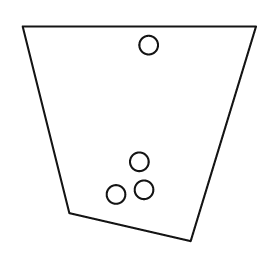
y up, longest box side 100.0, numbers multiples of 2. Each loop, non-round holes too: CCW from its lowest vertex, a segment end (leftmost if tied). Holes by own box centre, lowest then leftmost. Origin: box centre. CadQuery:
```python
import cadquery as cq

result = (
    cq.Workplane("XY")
    .moveTo(22.0, -46.0)
    .lineTo(50.0, 46.0)
    .lineTo(-50.0, 46.0)
    .lineTo(-30.0, -34.0)
    .close()
    .moveTo(-10.0, -26.0)
    .circle(4.0)
    .moveTo(2.0, -24.0)
    .circle(4.0)
    .moveTo(0.0, -12.0)
    .circle(4.0)
    .moveTo(4.0, 38.0)
    .circle(4.0)
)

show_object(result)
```